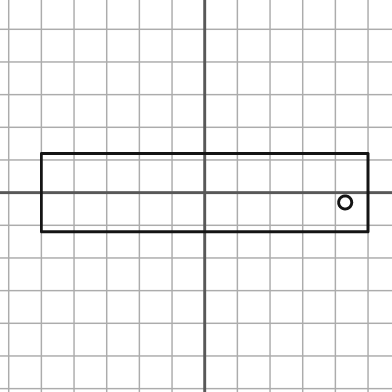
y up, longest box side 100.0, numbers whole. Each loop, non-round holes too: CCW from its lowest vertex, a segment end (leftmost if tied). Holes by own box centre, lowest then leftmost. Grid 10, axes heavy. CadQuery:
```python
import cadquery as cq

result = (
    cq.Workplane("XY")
    .moveTo(-50.0, -12.0)
    .lineTo(50.0, -12.0)
    .lineTo(50.0, 12.0)
    .lineTo(-50.0, 12.0)
    .close()
    .moveTo(43.0, -3.0)
    .circle(2.0)
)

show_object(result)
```